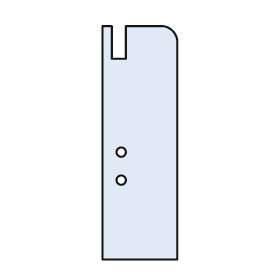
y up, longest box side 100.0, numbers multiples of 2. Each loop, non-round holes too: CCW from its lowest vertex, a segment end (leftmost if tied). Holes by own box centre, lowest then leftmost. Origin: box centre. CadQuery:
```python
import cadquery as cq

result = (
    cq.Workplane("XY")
    .moveTo(-16.0, -50.0)
    .lineTo(16.0, -50.0)
    .lineTo(16.0, 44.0)
    .threePointArc((14.0, 48.0), (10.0, 50.0))
    .lineTo(-6.0, 50.0)
    .lineTo(-6.0, 36.0)
    .lineTo(-12.0, 36.0)
    .lineTo(-12.0, 50.0)
    .lineTo(-16.0, 50.0)
    .close()
    .moveTo(-8.0, -16.0)
    .circle(2.0)
    .moveTo(-8.0, -4.0)
    .circle(2.0)
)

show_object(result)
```